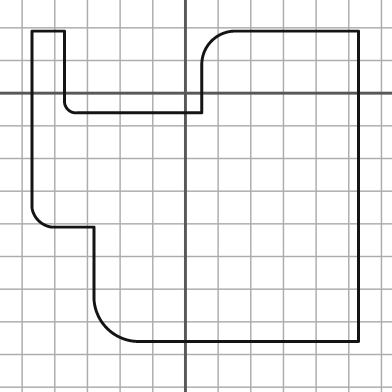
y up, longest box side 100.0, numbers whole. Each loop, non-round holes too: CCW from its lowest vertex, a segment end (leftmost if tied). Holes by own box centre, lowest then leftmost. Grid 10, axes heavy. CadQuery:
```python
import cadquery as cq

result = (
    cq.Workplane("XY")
    .moveTo(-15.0, -76.0)
    .lineTo(53.0, -76.0)
    .lineTo(53.0, 19.0)
    .lineTo(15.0, 19.0)
    .threePointArc((8.0, 16.0), (5.0, 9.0))
    .lineTo(5.0, -6.0)
    .lineTo(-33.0, -6.0)
    .threePointArc((-36.0, -5.0), (-37.0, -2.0))
    .lineTo(-37.0, 19.0)
    .lineTo(-47.0, 19.0)
    .lineTo(-47.0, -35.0)
    .threePointArc((-45.0, -39.0), (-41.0, -41.0))
    .lineTo(-28.0, -41.0)
    .lineTo(-28.0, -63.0)
    .threePointArc((-24.0, -72.0), (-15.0, -76.0))
    .close()
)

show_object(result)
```